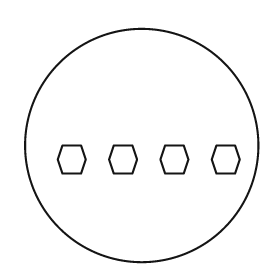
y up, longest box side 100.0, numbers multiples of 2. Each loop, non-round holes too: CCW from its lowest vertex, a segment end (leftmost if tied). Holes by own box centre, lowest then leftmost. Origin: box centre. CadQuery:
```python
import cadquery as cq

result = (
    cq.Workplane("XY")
    .moveTo(0.0, 0.0)
    .circle(50.0)
    .moveTo(-34.0, -12.0)
    .lineTo(-26.0, -12.0)
    .lineTo(-24.0, -6.0)
    .lineTo(-26.0, 0.0)
    .lineTo(-34.0, 0.0)
    .lineTo(-36.0, -6.0)
    .close()
    .moveTo(-12.0, -12.0)
    .lineTo(-4.0, -12.0)
    .lineTo(-2.0, -6.0)
    .lineTo(-4.0, 0.0)
    .lineTo(-12.0, 0.0)
    .lineTo(-14.0, -6.0)
    .close()
    .moveTo(10.0, -12.0)
    .lineTo(18.0, -12.0)
    .lineTo(20.0, -6.0)
    .lineTo(18.0, 0.0)
    .lineTo(10.0, 0.0)
    .lineTo(8.0, -6.0)
    .close()
    .moveTo(32.0, -12.0)
    .lineTo(40.0, -12.0)
    .lineTo(42.0, -6.0)
    .lineTo(40.0, 0.0)
    .lineTo(32.0, 0.0)
    .lineTo(30.0, -6.0)
    .close()
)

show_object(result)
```